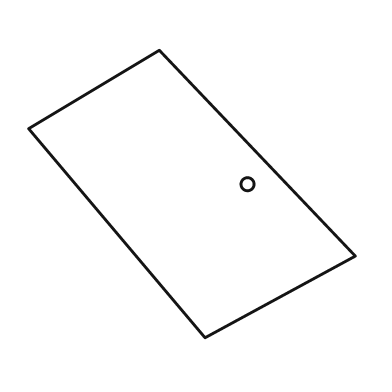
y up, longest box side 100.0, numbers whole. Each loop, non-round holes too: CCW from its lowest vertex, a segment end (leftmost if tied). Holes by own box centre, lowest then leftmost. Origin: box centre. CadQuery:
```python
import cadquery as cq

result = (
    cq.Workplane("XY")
    .moveTo(4.0, -44.0)
    .lineTo(50.0, -19.0)
    .lineTo(-10.0, 44.0)
    .lineTo(-50.0, 20.0)
    .close()
    .moveTo(17.0, 3.0)
    .circle(2.0)
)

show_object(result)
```